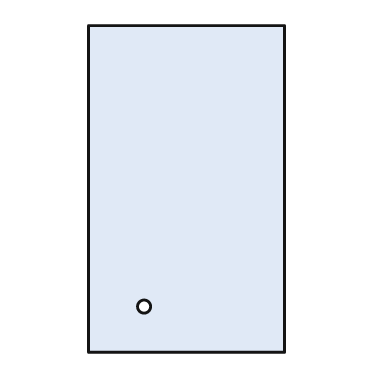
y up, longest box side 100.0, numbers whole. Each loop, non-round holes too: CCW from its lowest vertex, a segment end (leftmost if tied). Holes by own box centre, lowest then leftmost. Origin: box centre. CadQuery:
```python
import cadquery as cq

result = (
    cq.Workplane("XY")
    .moveTo(-30.0, -50.0)
    .lineTo(30.0, -50.0)
    .lineTo(30.0, 50.0)
    .lineTo(-30.0, 50.0)
    .close()
    .moveTo(-13.0, -36.0)
    .circle(2.0)
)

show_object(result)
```